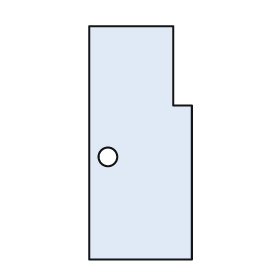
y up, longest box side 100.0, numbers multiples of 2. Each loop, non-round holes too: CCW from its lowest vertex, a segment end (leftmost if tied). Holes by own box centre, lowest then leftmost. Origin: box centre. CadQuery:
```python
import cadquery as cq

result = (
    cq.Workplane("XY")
    .moveTo(-22.0, -50.0)
    .lineTo(22.0, -50.0)
    .lineTo(22.0, 16.0)
    .lineTo(14.0, 16.0)
    .lineTo(14.0, 50.0)
    .lineTo(-22.0, 50.0)
    .close()
    .moveTo(-14.0, -6.0)
    .circle(4.0)
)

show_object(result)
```